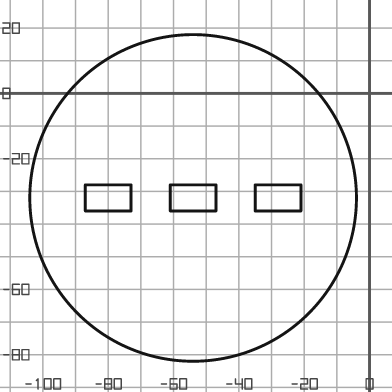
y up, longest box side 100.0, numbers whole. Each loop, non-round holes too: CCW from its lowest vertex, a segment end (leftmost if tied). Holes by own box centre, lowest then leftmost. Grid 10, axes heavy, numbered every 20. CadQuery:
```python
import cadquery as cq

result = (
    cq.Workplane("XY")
    .moveTo(-54.0, -32.0)
    .circle(50.0)
    .moveTo(-87.0, -36.0)
    .lineTo(-73.0, -36.0)
    .lineTo(-73.0, -28.0)
    .lineTo(-87.0, -28.0)
    .close()
    .moveTo(-61.0, -36.0)
    .lineTo(-47.0, -36.0)
    .lineTo(-47.0, -28.0)
    .lineTo(-61.0, -28.0)
    .close()
    .moveTo(-35.0, -36.0)
    .lineTo(-21.0, -36.0)
    .lineTo(-21.0, -28.0)
    .lineTo(-35.0, -28.0)
    .close()
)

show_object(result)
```